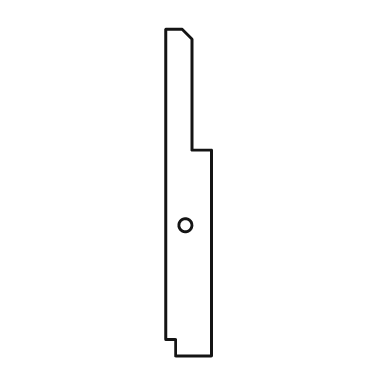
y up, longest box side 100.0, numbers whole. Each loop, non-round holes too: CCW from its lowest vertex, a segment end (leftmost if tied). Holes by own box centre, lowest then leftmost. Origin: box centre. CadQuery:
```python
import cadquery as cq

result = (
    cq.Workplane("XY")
    .moveTo(-4.0, -50.0)
    .lineTo(7.0, -50.0)
    .lineTo(7.0, 13.0)
    .lineTo(1.0, 13.0)
    .lineTo(1.0, 47.0)
    .lineTo(-2.0, 50.0)
    .lineTo(-7.0, 50.0)
    .lineTo(-7.0, -45.0)
    .lineTo(-4.0, -45.0)
    .close()
    .moveTo(-1.0, -10.0)
    .circle(2.0)
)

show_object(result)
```